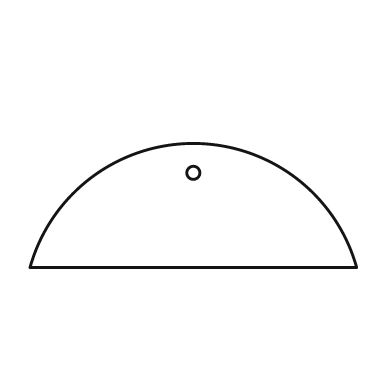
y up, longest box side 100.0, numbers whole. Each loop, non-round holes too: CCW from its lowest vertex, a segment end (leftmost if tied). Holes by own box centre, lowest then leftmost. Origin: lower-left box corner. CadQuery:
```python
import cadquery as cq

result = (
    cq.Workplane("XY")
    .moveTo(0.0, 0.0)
    .lineTo(100.0, 0.0)
    .threePointArc((50.0, 38.0), (0.0, 0.0))
    .close()
    .moveTo(50.0, 29.0)
    .circle(2.0)
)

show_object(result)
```